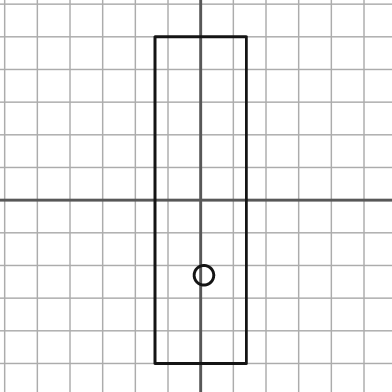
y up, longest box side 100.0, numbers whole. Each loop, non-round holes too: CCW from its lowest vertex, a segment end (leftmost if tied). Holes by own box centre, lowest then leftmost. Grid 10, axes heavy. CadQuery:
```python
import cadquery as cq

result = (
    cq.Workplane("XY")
    .moveTo(-14.0, -50.0)
    .lineTo(14.0, -50.0)
    .lineTo(14.0, 50.0)
    .lineTo(-14.0, 50.0)
    .close()
    .moveTo(1.0, -23.0)
    .circle(3.0)
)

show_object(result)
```